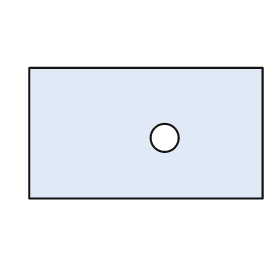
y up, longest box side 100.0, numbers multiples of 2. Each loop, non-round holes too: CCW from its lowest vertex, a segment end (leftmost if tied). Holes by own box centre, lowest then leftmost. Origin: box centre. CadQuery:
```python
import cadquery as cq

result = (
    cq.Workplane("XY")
    .moveTo(-50.0, -28.0)
    .lineTo(50.0, -28.0)
    .lineTo(50.0, 28.0)
    .lineTo(-50.0, 28.0)
    .close()
    .moveTo(8.0, -2.0)
    .circle(6.0)
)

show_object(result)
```